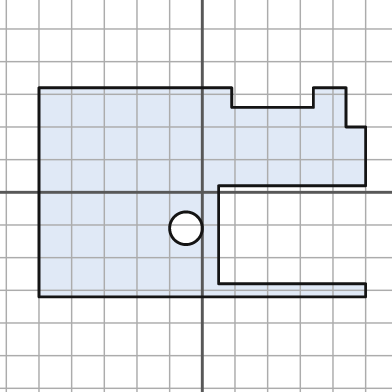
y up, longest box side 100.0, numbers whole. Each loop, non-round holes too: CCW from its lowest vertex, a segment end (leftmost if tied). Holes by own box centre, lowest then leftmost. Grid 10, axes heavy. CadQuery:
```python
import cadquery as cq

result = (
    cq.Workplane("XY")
    .moveTo(-50.0, -32.0)
    .lineTo(50.0, -32.0)
    .lineTo(50.0, -28.0)
    .lineTo(5.0, -28.0)
    .lineTo(5.0, 2.0)
    .lineTo(50.0, 2.0)
    .lineTo(50.0, 20.0)
    .lineTo(44.0, 20.0)
    .lineTo(44.0, 32.0)
    .lineTo(34.0, 32.0)
    .lineTo(34.0, 26.0)
    .lineTo(9.0, 26.0)
    .lineTo(9.0, 32.0)
    .lineTo(-50.0, 32.0)
    .close()
    .moveTo(-5.0, -11.0)
    .circle(5.0)
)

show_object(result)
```